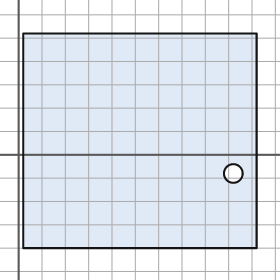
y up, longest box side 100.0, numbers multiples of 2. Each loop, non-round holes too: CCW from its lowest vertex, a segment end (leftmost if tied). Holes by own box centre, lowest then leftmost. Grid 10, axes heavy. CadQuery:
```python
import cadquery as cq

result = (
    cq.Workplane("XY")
    .moveTo(2.0, -40.0)
    .lineTo(102.0, -40.0)
    .lineTo(102.0, 52.0)
    .lineTo(2.0, 52.0)
    .close()
    .moveTo(92.0, -8.0)
    .circle(4.0)
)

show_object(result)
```